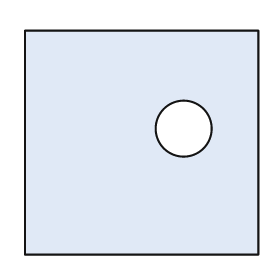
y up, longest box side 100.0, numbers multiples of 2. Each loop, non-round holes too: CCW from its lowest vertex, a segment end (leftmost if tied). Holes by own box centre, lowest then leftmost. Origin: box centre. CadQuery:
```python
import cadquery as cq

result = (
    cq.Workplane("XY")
    .moveTo(-50.0, -48.0)
    .lineTo(50.0, -48.0)
    .lineTo(50.0, 48.0)
    .lineTo(-50.0, 48.0)
    .close()
    .moveTo(18.0, 6.0)
    .circle(12.0)
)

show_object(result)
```